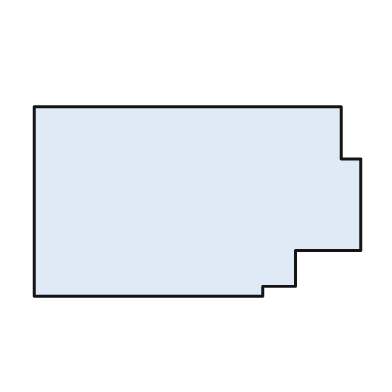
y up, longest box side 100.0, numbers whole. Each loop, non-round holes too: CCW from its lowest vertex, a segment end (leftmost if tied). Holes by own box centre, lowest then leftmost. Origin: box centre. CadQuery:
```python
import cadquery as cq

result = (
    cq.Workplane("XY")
    .moveTo(-50.0, -29.0)
    .lineTo(20.0, -29.0)
    .lineTo(20.0, -26.0)
    .lineTo(30.0, -26.0)
    .lineTo(30.0, -15.0)
    .lineTo(50.0, -15.0)
    .lineTo(50.0, 13.0)
    .lineTo(44.0, 13.0)
    .lineTo(44.0, 29.0)
    .lineTo(-50.0, 29.0)
    .close()
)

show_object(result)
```